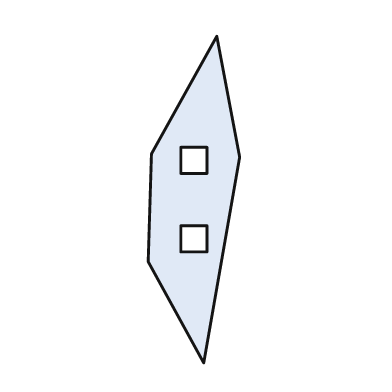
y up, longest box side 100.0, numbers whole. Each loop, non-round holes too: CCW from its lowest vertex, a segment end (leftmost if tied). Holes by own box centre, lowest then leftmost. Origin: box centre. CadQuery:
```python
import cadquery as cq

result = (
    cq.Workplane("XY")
    .moveTo(3.0, -50.0)
    .lineTo(14.0, 13.0)
    .lineTo(7.0, 50.0)
    .lineTo(-13.0, 14.0)
    .lineTo(-14.0, -19.0)
    .close()
    .moveTo(-4.0, -16.0)
    .lineTo(4.0, -16.0)
    .lineTo(4.0, -8.0)
    .lineTo(-4.0, -8.0)
    .close()
    .moveTo(-4.0, 8.0)
    .lineTo(4.0, 8.0)
    .lineTo(4.0, 16.0)
    .lineTo(-4.0, 16.0)
    .close()
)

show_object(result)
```